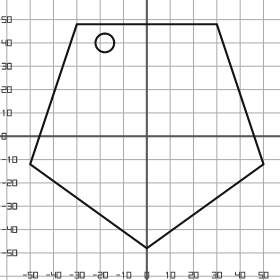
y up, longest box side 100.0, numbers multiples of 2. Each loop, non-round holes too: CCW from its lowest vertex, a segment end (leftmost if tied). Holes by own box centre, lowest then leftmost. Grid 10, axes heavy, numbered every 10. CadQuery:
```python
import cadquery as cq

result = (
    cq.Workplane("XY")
    .moveTo(0.0, -48.0)
    .lineTo(50.0, -12.0)
    .lineTo(30.0, 48.0)
    .lineTo(-30.0, 48.0)
    .lineTo(-50.0, -12.0)
    .close()
    .moveTo(-18.0, 40.0)
    .circle(4.0)
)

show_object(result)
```